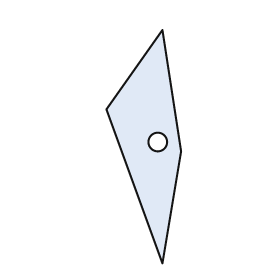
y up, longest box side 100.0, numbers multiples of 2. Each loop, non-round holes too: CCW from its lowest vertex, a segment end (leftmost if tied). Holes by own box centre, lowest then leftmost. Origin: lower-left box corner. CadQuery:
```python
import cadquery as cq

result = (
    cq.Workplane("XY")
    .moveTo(24.0, 0.0)
    .lineTo(32.0, 48.0)
    .lineTo(24.0, 100.0)
    .lineTo(0.0, 66.0)
    .close()
    .moveTo(22.0, 52.0)
    .circle(4.0)
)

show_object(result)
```